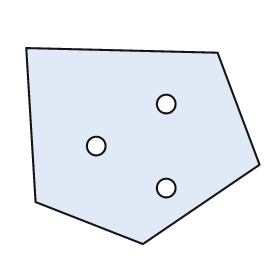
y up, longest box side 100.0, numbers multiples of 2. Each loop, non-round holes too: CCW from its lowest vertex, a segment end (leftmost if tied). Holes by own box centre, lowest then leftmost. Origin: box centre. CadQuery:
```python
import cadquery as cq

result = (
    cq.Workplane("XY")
    .moveTo(0.0, -42.0)
    .lineTo(50.0, -8.0)
    .lineTo(32.0, 40.0)
    .lineTo(-50.0, 42.0)
    .lineTo(-46.0, -24.0)
    .close()
    .moveTo(10.0, -18.0)
    .circle(4.0)
    .moveTo(-20.0, 0.0)
    .circle(4.0)
    .moveTo(10.0, 18.0)
    .circle(4.0)
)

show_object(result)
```